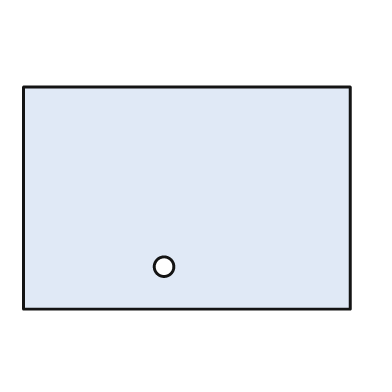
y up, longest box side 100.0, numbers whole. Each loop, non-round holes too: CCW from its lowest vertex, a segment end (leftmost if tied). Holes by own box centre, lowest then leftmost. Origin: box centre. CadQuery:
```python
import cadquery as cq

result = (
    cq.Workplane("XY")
    .moveTo(-50.0, -34.0)
    .lineTo(50.0, -34.0)
    .lineTo(50.0, 34.0)
    .lineTo(-50.0, 34.0)
    .close()
    .moveTo(-7.0, -21.0)
    .circle(3.0)
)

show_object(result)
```